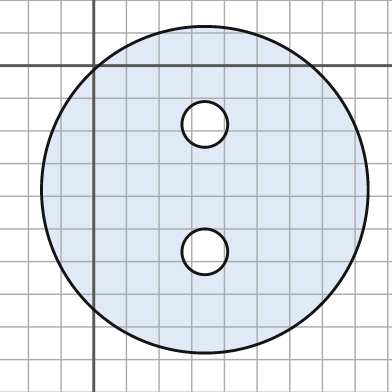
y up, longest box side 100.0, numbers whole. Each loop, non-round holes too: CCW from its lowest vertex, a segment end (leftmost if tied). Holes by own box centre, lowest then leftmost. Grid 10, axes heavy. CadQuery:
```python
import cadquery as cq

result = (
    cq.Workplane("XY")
    .moveTo(34.0, -38.0)
    .circle(50.0)
    .moveTo(34.0, -57.0)
    .circle(7.0)
    .moveTo(34.0, -18.0)
    .circle(7.0)
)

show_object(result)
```